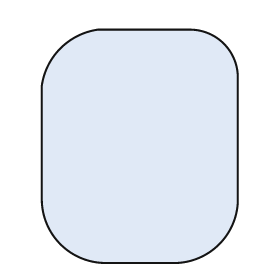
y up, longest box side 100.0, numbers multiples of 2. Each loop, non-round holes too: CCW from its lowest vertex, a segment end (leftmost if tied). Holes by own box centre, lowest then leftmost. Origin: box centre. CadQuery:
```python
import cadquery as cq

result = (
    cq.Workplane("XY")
    .moveTo(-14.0, -50.0)
    .lineTo(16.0, -50.0)
    .threePointArc((34.0, -42.0), (42.0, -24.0))
    .lineTo(42.0, 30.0)
    .threePointArc((36.0, 44.0), (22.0, 50.0))
    .lineTo(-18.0, 50.0)
    .threePointArc((-34.0, 42.0), (-42.0, 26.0))
    .lineTo(-42.0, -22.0)
    .threePointArc((-34.0, -42.0), (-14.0, -50.0))
    .close()
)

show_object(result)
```